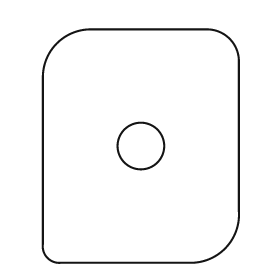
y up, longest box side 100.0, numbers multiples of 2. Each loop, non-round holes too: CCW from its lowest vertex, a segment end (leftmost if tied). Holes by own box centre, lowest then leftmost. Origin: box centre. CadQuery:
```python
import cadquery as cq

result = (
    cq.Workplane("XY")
    .moveTo(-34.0, -50.0)
    .lineTo(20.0, -50.0)
    .threePointArc((36.0, -44.0), (42.0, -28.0))
    .lineTo(42.0, 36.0)
    .threePointArc((38.0, 46.0), (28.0, 50.0))
    .lineTo(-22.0, 50.0)
    .threePointArc((-36.0, 44.0), (-42.0, 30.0))
    .lineTo(-42.0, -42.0)
    .threePointArc((-40.0, -48.0), (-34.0, -50.0))
    .close()
    .moveTo(0.0, 0.0)
    .circle(10.0)
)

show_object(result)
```